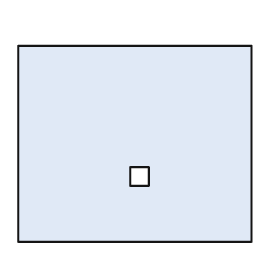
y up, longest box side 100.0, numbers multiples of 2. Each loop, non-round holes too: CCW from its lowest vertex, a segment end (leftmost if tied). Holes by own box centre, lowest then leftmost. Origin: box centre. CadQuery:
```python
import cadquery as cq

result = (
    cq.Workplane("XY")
    .moveTo(-50.0, -42.0)
    .lineTo(50.0, -42.0)
    .lineTo(50.0, 42.0)
    .lineTo(-50.0, 42.0)
    .close()
    .moveTo(-2.0, -18.0)
    .lineTo(6.0, -18.0)
    .lineTo(6.0, -10.0)
    .lineTo(-2.0, -10.0)
    .close()
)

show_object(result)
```